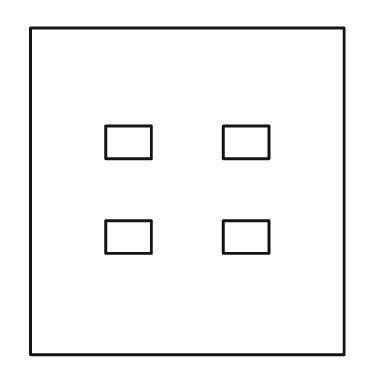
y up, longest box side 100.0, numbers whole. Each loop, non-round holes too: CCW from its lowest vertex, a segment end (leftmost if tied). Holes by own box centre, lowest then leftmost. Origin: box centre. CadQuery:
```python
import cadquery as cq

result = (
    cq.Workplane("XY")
    .moveTo(-48.0, -50.0)
    .lineTo(48.0, -50.0)
    .lineTo(48.0, 50.0)
    .lineTo(-48.0, 50.0)
    .close()
    .moveTo(-25.0, -19.0)
    .lineTo(-11.0, -19.0)
    .lineTo(-11.0, -9.0)
    .lineTo(-25.0, -9.0)
    .close()
    .moveTo(11.0, -19.0)
    .lineTo(25.0, -19.0)
    .lineTo(25.0, -9.0)
    .lineTo(11.0, -9.0)
    .close()
    .moveTo(-25.0, 10.0)
    .lineTo(-11.0, 10.0)
    .lineTo(-11.0, 20.0)
    .lineTo(-25.0, 20.0)
    .close()
    .moveTo(11.0, 10.0)
    .lineTo(25.0, 10.0)
    .lineTo(25.0, 20.0)
    .lineTo(11.0, 20.0)
    .close()
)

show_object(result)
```